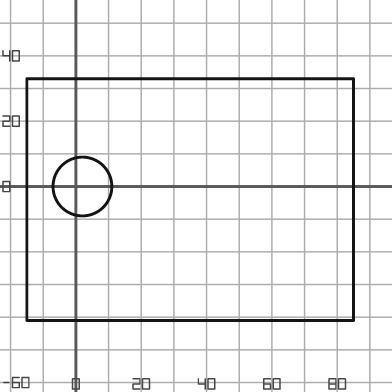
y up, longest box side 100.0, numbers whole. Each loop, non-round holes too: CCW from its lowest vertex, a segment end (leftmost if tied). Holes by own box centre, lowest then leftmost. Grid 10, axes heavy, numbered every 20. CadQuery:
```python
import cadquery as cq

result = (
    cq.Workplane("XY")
    .moveTo(-15.0, -41.0)
    .lineTo(85.0, -41.0)
    .lineTo(85.0, 33.0)
    .lineTo(-15.0, 33.0)
    .close()
    .moveTo(2.0, 0.0)
    .circle(9.0)
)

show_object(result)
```